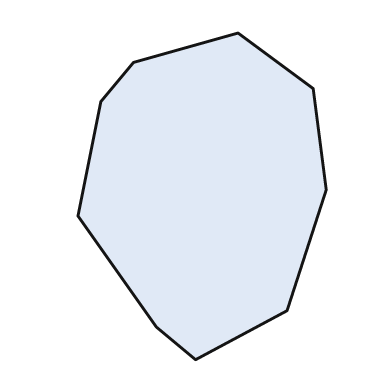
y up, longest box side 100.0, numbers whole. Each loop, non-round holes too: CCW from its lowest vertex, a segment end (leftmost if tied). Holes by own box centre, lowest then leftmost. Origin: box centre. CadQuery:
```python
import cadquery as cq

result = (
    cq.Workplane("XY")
    .moveTo(-2.0, -50.0)
    .lineTo(26.0, -35.0)
    .lineTo(38.0, 2.0)
    .lineTo(34.0, 33.0)
    .lineTo(11.0, 50.0)
    .lineTo(-21.0, 41.0)
    .lineTo(-31.0, 29.0)
    .lineTo(-38.0, -6.0)
    .lineTo(-14.0, -40.0)
    .close()
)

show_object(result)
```